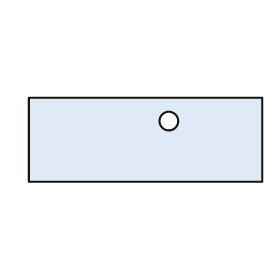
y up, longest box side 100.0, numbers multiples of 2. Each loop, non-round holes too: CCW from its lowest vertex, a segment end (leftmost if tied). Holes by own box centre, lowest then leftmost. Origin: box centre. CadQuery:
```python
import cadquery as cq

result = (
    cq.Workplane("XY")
    .moveTo(-50.0, -18.0)
    .lineTo(50.0, -18.0)
    .lineTo(50.0, 18.0)
    .lineTo(-50.0, 18.0)
    .close()
    .moveTo(10.0, 8.0)
    .circle(4.0)
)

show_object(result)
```